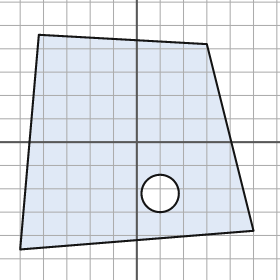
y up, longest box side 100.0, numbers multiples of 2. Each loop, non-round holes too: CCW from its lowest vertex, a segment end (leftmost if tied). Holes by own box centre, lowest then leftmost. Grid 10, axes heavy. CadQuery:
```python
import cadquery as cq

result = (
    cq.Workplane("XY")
    .moveTo(-50.0, -46.0)
    .lineTo(50.0, -38.0)
    .lineTo(30.0, 42.0)
    .lineTo(-42.0, 46.0)
    .close()
    .moveTo(10.0, -22.0)
    .circle(8.0)
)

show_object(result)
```